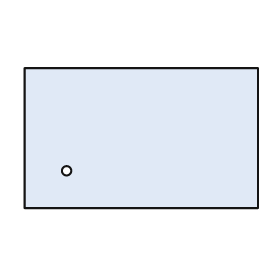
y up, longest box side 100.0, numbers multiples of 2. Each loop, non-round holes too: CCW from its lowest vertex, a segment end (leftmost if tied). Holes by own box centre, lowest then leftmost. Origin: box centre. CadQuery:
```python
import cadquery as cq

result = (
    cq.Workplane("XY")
    .moveTo(-50.0, -30.0)
    .lineTo(50.0, -30.0)
    .lineTo(50.0, 30.0)
    .lineTo(-50.0, 30.0)
    .close()
    .moveTo(-32.0, -14.0)
    .circle(2.0)
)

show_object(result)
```